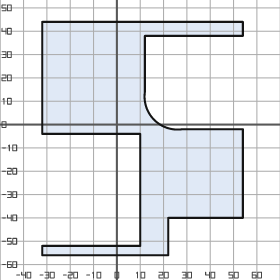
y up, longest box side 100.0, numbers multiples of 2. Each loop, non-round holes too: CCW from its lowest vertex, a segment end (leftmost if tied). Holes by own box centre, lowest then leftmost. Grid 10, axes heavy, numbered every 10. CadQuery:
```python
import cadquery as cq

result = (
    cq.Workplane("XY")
    .moveTo(-32.0, -56.0)
    .lineTo(22.0, -56.0)
    .lineTo(22.0, -40.0)
    .lineTo(54.0, -40.0)
    .lineTo(54.0, -2.0)
    .lineTo(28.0, -2.0)
    .threePointArc((16.0, 2.0), (12.0, 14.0))
    .lineTo(12.0, 38.0)
    .lineTo(54.0, 38.0)
    .lineTo(54.0, 44.0)
    .lineTo(-32.0, 44.0)
    .lineTo(-32.0, -4.0)
    .lineTo(10.0, -4.0)
    .lineTo(10.0, -52.0)
    .lineTo(-32.0, -52.0)
    .close()
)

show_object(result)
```